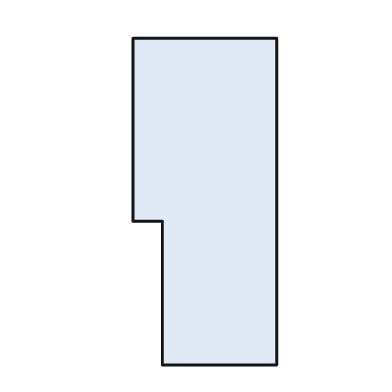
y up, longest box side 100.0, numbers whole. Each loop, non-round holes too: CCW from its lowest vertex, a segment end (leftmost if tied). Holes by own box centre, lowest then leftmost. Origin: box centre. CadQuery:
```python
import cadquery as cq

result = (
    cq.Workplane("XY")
    .moveTo(-13.0, -50.0)
    .lineTo(22.0, -50.0)
    .lineTo(22.0, 50.0)
    .lineTo(-22.0, 50.0)
    .lineTo(-22.0, -6.0)
    .lineTo(-13.0, -6.0)
    .close()
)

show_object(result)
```